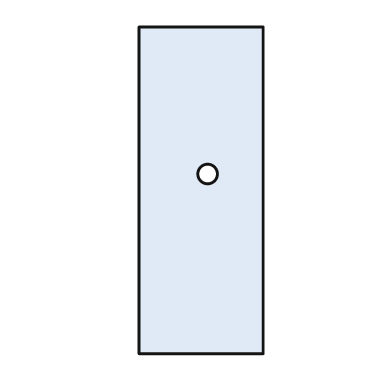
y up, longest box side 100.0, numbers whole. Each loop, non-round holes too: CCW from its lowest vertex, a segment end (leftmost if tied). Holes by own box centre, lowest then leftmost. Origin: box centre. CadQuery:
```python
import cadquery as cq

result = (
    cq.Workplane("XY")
    .moveTo(-19.0, -50.0)
    .lineTo(19.0, -50.0)
    .lineTo(19.0, 50.0)
    .lineTo(-19.0, 50.0)
    .close()
    .moveTo(2.0, 5.0)
    .circle(3.0)
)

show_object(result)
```